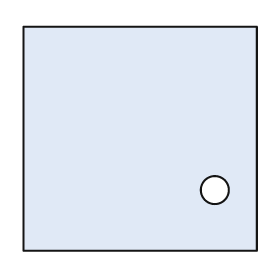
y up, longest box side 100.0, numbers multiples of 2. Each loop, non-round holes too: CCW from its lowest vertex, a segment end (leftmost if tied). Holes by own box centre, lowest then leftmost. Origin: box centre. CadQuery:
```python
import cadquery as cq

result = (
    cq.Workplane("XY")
    .moveTo(-50.0, -48.0)
    .lineTo(50.0, -48.0)
    .lineTo(50.0, 48.0)
    .lineTo(-50.0, 48.0)
    .close()
    .moveTo(32.0, -22.0)
    .circle(6.0)
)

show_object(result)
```